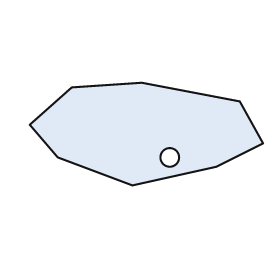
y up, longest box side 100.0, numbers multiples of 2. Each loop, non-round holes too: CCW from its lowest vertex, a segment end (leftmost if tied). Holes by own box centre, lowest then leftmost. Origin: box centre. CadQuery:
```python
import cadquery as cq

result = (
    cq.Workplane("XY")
    .moveTo(-6.0, -22.0)
    .lineTo(30.0, -14.0)
    .lineTo(50.0, -4.0)
    .lineTo(40.0, 14.0)
    .lineTo(-2.0, 22.0)
    .lineTo(-32.0, 20.0)
    .lineTo(-50.0, 4.0)
    .lineTo(-38.0, -10.0)
    .close()
    .moveTo(10.0, -10.0)
    .circle(4.0)
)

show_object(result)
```